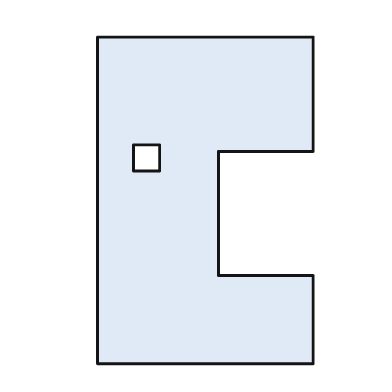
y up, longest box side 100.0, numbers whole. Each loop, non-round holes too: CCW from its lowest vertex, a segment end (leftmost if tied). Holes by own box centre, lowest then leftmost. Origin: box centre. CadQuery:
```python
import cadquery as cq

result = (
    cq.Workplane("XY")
    .moveTo(-33.0, -50.0)
    .lineTo(33.0, -50.0)
    .lineTo(33.0, -23.0)
    .lineTo(4.0, -23.0)
    .lineTo(4.0, 15.0)
    .lineTo(33.0, 15.0)
    .lineTo(33.0, 50.0)
    .lineTo(-33.0, 50.0)
    .close()
    .moveTo(-22.0, 9.0)
    .lineTo(-14.0, 9.0)
    .lineTo(-14.0, 17.0)
    .lineTo(-22.0, 17.0)
    .close()
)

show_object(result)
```